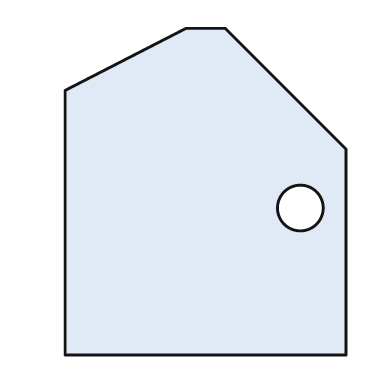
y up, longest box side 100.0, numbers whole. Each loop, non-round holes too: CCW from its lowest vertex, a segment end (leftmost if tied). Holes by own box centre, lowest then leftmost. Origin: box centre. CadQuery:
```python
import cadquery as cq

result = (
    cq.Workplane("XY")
    .moveTo(-43.0, -50.0)
    .lineTo(43.0, -50.0)
    .lineTo(43.0, 13.0)
    .lineTo(6.0, 50.0)
    .lineTo(-6.0, 50.0)
    .lineTo(-43.0, 31.0)
    .close()
    .moveTo(29.0, -5.0)
    .circle(7.0)
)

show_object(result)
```